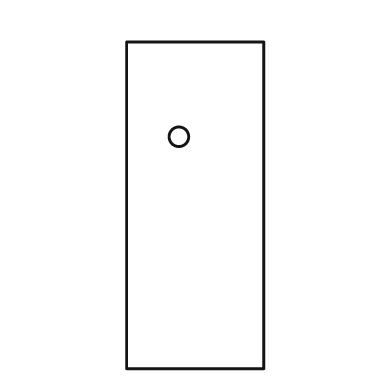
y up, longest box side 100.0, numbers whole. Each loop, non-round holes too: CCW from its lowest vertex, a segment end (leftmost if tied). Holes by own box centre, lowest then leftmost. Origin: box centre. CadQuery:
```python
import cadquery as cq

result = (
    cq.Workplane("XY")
    .moveTo(-21.0, -50.0)
    .lineTo(21.0, -50.0)
    .lineTo(21.0, 50.0)
    .lineTo(-21.0, 50.0)
    .close()
    .moveTo(-5.0, 21.0)
    .circle(3.0)
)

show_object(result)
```